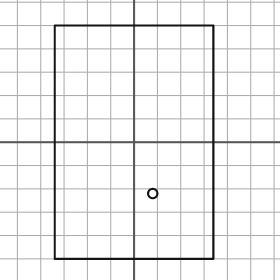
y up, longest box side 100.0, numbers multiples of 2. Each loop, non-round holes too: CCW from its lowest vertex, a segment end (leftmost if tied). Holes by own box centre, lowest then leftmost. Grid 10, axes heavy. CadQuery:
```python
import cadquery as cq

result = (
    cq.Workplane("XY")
    .moveTo(-34.0, -50.0)
    .lineTo(34.0, -50.0)
    .lineTo(34.0, 50.0)
    .lineTo(-34.0, 50.0)
    .close()
    .moveTo(8.0, -22.0)
    .circle(2.0)
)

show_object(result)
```